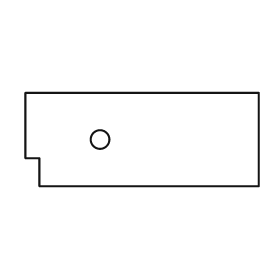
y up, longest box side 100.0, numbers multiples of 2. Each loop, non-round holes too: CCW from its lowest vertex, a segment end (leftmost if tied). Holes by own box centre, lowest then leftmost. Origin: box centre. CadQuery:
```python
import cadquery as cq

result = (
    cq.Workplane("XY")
    .moveTo(-44.0, -20.0)
    .lineTo(50.0, -20.0)
    .lineTo(50.0, 20.0)
    .lineTo(-50.0, 20.0)
    .lineTo(-50.0, -8.0)
    .lineTo(-44.0, -8.0)
    .close()
    .moveTo(-18.0, 0.0)
    .circle(4.0)
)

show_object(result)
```